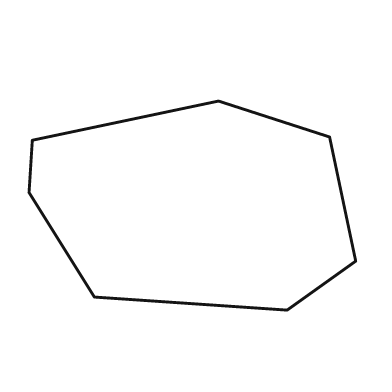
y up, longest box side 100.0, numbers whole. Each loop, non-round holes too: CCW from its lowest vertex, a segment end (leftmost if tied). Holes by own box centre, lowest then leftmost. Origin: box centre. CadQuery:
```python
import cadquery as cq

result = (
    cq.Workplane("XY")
    .moveTo(29.0, -32.0)
    .lineTo(50.0, -17.0)
    .lineTo(42.0, 21.0)
    .lineTo(8.0, 32.0)
    .lineTo(-49.0, 20.0)
    .lineTo(-50.0, 4.0)
    .lineTo(-30.0, -28.0)
    .close()
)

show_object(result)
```